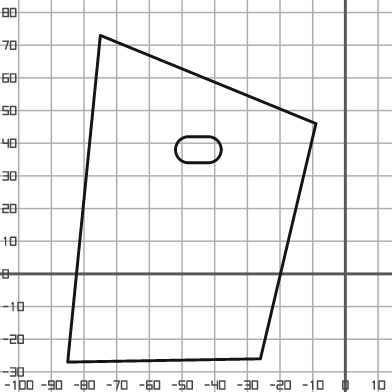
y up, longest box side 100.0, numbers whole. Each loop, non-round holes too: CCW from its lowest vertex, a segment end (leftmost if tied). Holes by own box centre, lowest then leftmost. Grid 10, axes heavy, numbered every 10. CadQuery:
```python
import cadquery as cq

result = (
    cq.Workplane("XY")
    .moveTo(-85.0, -27.0)
    .lineTo(-26.0, -26.0)
    .lineTo(-9.0, 46.0)
    .lineTo(-75.0, 73.0)
    .close()
    .moveTo(-48.0, 34.0)
    .lineTo(-42.0, 34.0)
    .threePointArc((-38.0, 38.0), (-42.0, 42.0))
    .lineTo(-48.0, 42.0)
    .threePointArc((-52.0, 38.0), (-48.0, 34.0))
    .close()
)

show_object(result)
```